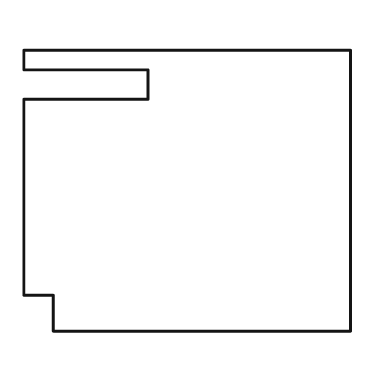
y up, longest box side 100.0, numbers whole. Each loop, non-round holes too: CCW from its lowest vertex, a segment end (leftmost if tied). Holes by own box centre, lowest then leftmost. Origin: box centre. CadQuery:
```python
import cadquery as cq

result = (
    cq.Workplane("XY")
    .moveTo(-41.0, -43.0)
    .lineTo(50.0, -43.0)
    .lineTo(50.0, 43.0)
    .lineTo(-50.0, 43.0)
    .lineTo(-50.0, 37.0)
    .lineTo(-12.0, 37.0)
    .lineTo(-12.0, 28.0)
    .lineTo(-50.0, 28.0)
    .lineTo(-50.0, -32.0)
    .lineTo(-41.0, -32.0)
    .close()
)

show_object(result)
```